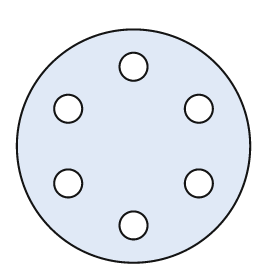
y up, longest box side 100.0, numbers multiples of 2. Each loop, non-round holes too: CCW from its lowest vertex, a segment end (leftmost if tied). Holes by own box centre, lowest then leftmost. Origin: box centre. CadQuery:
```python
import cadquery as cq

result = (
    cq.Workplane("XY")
    .moveTo(0.0, 0.0)
    .circle(50.0)
    .moveTo(0.0, -34.0)
    .circle(6.0)
    .moveTo(-28.0, -16.0)
    .circle(6.0)
    .moveTo(28.0, -16.0)
    .circle(6.0)
    .moveTo(-28.0, 16.0)
    .circle(6.0)
    .moveTo(28.0, 16.0)
    .circle(6.0)
    .moveTo(0.0, 34.0)
    .circle(6.0)
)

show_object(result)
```